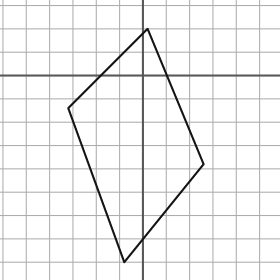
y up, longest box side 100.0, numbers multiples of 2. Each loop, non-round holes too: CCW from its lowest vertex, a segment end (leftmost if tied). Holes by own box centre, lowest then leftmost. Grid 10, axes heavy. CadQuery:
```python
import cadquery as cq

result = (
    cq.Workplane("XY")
    .moveTo(-8.0, -80.0)
    .lineTo(26.0, -38.0)
    .lineTo(2.0, 20.0)
    .lineTo(-32.0, -14.0)
    .close()
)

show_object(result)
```